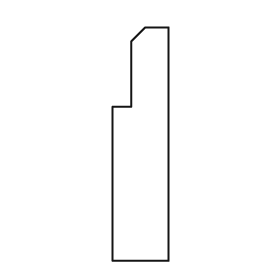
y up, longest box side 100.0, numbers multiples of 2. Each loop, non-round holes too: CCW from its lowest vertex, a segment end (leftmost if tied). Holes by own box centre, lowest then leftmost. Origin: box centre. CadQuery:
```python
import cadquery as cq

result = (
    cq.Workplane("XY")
    .moveTo(-12.0, -50.0)
    .lineTo(12.0, -50.0)
    .lineTo(12.0, 50.0)
    .lineTo(2.0, 50.0)
    .lineTo(-4.0, 44.0)
    .lineTo(-4.0, 16.0)
    .lineTo(-12.0, 16.0)
    .close()
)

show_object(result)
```